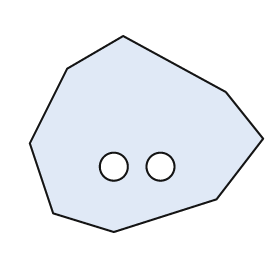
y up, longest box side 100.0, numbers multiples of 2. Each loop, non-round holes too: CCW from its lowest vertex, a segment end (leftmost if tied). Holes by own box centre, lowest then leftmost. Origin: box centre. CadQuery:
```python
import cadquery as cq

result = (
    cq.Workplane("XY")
    .moveTo(-14.0, -42.0)
    .lineTo(30.0, -28.0)
    .lineTo(50.0, -2.0)
    .lineTo(34.0, 18.0)
    .lineTo(-10.0, 42.0)
    .lineTo(-34.0, 28.0)
    .lineTo(-50.0, -4.0)
    .lineTo(-40.0, -34.0)
    .close()
    .moveTo(-14.0, -14.0)
    .circle(6.0)
    .moveTo(6.0, -14.0)
    .circle(6.0)
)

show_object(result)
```